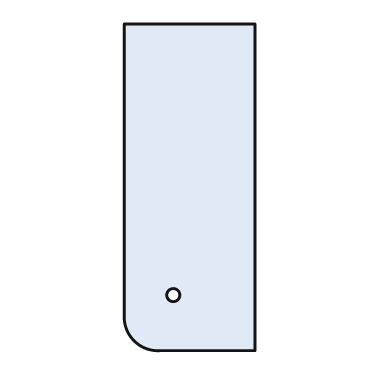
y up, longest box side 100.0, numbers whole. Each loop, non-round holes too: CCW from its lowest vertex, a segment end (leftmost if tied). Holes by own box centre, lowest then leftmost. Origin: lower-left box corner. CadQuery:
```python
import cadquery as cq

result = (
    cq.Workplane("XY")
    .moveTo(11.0, 0.0)
    .lineTo(40.0, 0.0)
    .lineTo(40.0, 100.0)
    .lineTo(0.0, 100.0)
    .lineTo(0.0, 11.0)
    .threePointArc((3.0, 3.0), (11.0, 0.0))
    .close()
    .moveTo(15.0, 17.0)
    .circle(2.0)
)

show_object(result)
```